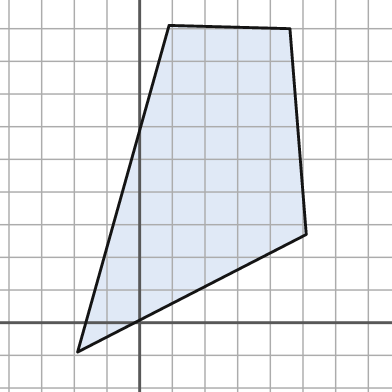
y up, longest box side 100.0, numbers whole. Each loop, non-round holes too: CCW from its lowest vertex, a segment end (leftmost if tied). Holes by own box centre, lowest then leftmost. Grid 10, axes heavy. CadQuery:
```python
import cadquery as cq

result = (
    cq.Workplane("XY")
    .moveTo(-19.0, -9.0)
    .lineTo(51.0, 27.0)
    .lineTo(46.0, 90.0)
    .lineTo(9.0, 91.0)
    .close()
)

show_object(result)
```